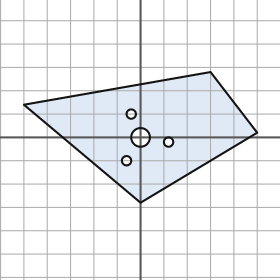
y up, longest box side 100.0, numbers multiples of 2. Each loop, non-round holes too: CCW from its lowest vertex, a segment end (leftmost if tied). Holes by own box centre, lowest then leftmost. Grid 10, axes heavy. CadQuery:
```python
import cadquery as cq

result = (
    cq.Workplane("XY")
    .moveTo(0.0, -28.0)
    .lineTo(50.0, 2.0)
    .lineTo(30.0, 28.0)
    .lineTo(-50.0, 14.0)
    .close()
    .moveTo(-6.0, -10.0)
    .circle(2.0)
    .moveTo(12.0, -2.0)
    .circle(2.0)
    .moveTo(0.0, 0.0)
    .circle(4.0)
    .moveTo(-4.0, 10.0)
    .circle(2.0)
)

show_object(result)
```